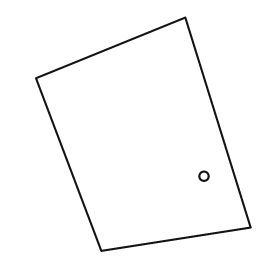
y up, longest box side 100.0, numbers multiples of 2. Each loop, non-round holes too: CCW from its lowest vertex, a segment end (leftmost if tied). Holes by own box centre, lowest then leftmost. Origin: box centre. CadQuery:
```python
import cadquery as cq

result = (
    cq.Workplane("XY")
    .moveTo(-18.0, -50.0)
    .lineTo(46.0, -40.0)
    .lineTo(18.0, 50.0)
    .lineTo(-46.0, 24.0)
    .close()
    .moveTo(26.0, -18.0)
    .circle(2.0)
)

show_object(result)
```